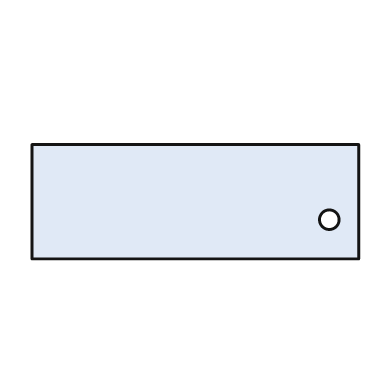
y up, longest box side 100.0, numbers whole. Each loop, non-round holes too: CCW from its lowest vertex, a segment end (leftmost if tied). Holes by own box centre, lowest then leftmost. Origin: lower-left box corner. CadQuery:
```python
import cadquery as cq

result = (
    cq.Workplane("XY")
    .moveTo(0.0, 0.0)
    .lineTo(100.0, 0.0)
    .lineTo(100.0, 35.0)
    .lineTo(0.0, 35.0)
    .close()
    .moveTo(91.0, 12.0)
    .circle(3.0)
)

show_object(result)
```